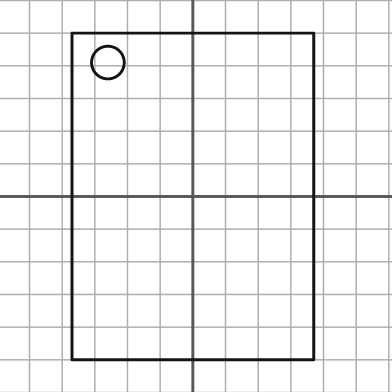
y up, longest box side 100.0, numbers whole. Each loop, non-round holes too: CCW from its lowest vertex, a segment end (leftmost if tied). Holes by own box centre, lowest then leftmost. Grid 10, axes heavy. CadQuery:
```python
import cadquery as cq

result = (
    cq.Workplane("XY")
    .moveTo(-37.0, -50.0)
    .lineTo(37.0, -50.0)
    .lineTo(37.0, 50.0)
    .lineTo(-37.0, 50.0)
    .close()
    .moveTo(-26.0, 41.0)
    .circle(5.0)
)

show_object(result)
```